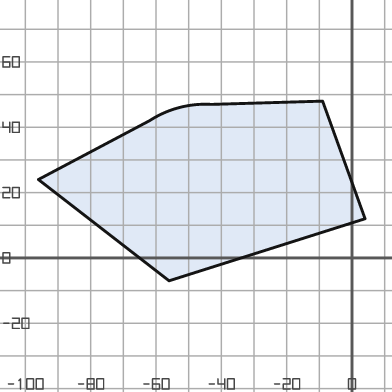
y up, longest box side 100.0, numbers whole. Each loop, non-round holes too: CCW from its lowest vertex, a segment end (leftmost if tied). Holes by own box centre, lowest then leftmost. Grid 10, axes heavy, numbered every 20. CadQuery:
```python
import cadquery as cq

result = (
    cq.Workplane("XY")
    .moveTo(-56.0, -7.0)
    .lineTo(4.0, 12.0)
    .lineTo(-9.0, 48.0)
    .lineTo(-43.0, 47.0)
    .threePointArc((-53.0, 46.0), (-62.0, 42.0))
    .lineTo(-96.0, 24.0)
    .close()
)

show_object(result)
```